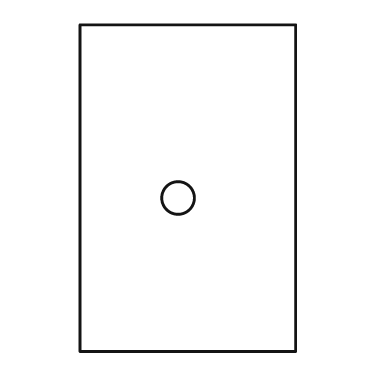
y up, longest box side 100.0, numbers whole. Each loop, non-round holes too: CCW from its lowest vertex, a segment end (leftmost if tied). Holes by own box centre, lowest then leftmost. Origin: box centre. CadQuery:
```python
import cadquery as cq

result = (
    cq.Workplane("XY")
    .moveTo(-33.0, -50.0)
    .lineTo(33.0, -50.0)
    .lineTo(33.0, 50.0)
    .lineTo(-33.0, 50.0)
    .close()
    .moveTo(-3.0, -3.0)
    .circle(5.0)
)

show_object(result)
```